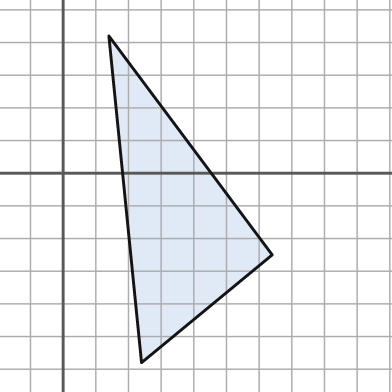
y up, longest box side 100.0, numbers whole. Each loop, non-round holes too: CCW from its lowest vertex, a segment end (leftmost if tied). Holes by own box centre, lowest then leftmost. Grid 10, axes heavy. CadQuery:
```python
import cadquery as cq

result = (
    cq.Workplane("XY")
    .moveTo(24.0, -58.0)
    .lineTo(64.0, -25.0)
    .lineTo(14.0, 42.0)
    .close()
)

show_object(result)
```